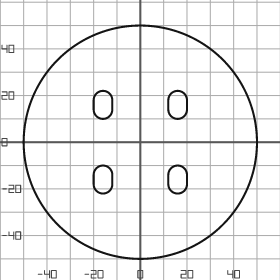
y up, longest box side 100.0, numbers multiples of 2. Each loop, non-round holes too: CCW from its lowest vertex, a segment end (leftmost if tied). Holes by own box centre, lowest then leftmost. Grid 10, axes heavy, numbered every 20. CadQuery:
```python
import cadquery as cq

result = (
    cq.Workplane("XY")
    .moveTo(0.0, 0.0)
    .circle(50.0)
    .moveTo(-20.0, -18.0)
    .threePointArc((-16.0, -22.0), (-12.0, -18.0))
    .lineTo(-12.0, -14.0)
    .threePointArc((-16.0, -10.0), (-20.0, -14.0))
    .close()
    .moveTo(12.0, -18.0)
    .threePointArc((16.0, -22.0), (20.0, -18.0))
    .lineTo(20.0, -14.0)
    .threePointArc((16.0, -10.0), (12.0, -14.0))
    .close()
    .moveTo(-20.0, 14.0)
    .threePointArc((-16.0, 10.0), (-12.0, 14.0))
    .lineTo(-12.0, 18.0)
    .threePointArc((-16.0, 22.0), (-20.0, 18.0))
    .close()
    .moveTo(12.0, 14.0)
    .threePointArc((16.0, 10.0), (20.0, 14.0))
    .lineTo(20.0, 18.0)
    .threePointArc((16.0, 22.0), (12.0, 18.0))
    .close()
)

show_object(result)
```